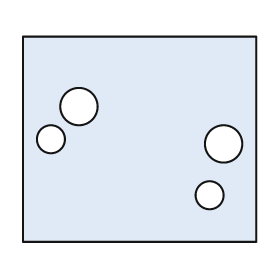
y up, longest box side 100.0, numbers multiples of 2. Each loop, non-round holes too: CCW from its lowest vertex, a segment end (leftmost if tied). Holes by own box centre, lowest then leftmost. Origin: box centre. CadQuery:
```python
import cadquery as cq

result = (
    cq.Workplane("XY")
    .moveTo(-50.0, -44.0)
    .lineTo(50.0, -44.0)
    .lineTo(50.0, 44.0)
    .lineTo(-50.0, 44.0)
    .close()
    .moveTo(30.0, -24.0)
    .circle(6.0)
    .moveTo(36.0, -2.0)
    .circle(8.0)
    .moveTo(-38.0, 0.0)
    .circle(6.0)
    .moveTo(-26.0, 14.0)
    .circle(8.0)
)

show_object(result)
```